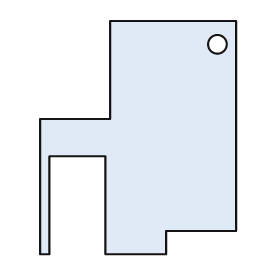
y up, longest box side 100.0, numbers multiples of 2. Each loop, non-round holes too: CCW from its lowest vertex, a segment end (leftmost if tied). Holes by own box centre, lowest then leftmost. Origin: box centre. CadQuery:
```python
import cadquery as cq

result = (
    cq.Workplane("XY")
    .moveTo(-42.0, -50.0)
    .lineTo(-38.0, -50.0)
    .lineTo(-38.0, -8.0)
    .lineTo(-14.0, -8.0)
    .lineTo(-14.0, -50.0)
    .lineTo(12.0, -50.0)
    .lineTo(12.0, -40.0)
    .lineTo(42.0, -40.0)
    .lineTo(42.0, 50.0)
    .lineTo(-12.0, 50.0)
    .lineTo(-12.0, 8.0)
    .lineTo(-42.0, 8.0)
    .close()
    .moveTo(34.0, 40.0)
    .circle(4.0)
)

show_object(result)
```